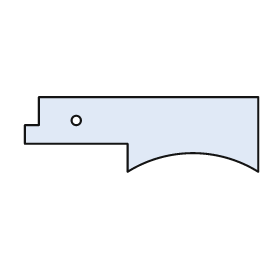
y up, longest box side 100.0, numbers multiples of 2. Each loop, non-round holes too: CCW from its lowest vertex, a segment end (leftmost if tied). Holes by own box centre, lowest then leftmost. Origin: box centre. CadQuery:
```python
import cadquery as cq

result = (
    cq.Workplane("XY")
    .moveTo(-6.0, -16.0)
    .threePointArc((22.0, -8.0), (50.0, -16.0))
    .lineTo(50.0, 16.0)
    .lineTo(-44.0, 16.0)
    .lineTo(-44.0, 4.0)
    .lineTo(-50.0, 4.0)
    .lineTo(-50.0, -4.0)
    .lineTo(-6.0, -4.0)
    .close()
    .moveTo(-28.0, 6.0)
    .circle(2.0)
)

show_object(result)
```